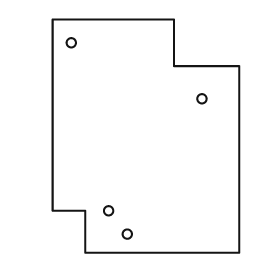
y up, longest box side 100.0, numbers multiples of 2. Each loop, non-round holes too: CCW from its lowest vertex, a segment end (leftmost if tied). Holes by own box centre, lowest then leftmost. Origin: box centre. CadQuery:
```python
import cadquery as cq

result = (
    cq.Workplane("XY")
    .moveTo(-26.0, -50.0)
    .lineTo(40.0, -50.0)
    .lineTo(40.0, 30.0)
    .lineTo(12.0, 30.0)
    .lineTo(12.0, 50.0)
    .lineTo(-40.0, 50.0)
    .lineTo(-40.0, -32.0)
    .lineTo(-26.0, -32.0)
    .close()
    .moveTo(-8.0, -42.0)
    .circle(2.0)
    .moveTo(-16.0, -32.0)
    .circle(2.0)
    .moveTo(24.0, 16.0)
    .circle(2.0)
    .moveTo(-32.0, 40.0)
    .circle(2.0)
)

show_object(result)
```